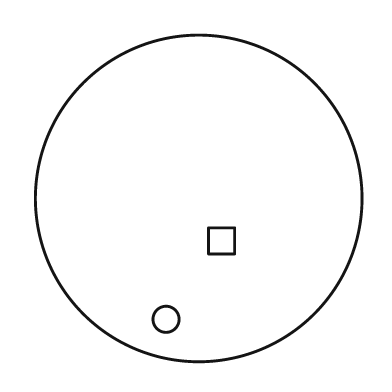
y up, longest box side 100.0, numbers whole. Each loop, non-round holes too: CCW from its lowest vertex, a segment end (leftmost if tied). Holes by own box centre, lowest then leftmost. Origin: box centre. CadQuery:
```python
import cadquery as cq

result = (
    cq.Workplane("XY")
    .moveTo(0.0, 0.0)
    .circle(50.0)
    .moveTo(-10.0, -37.0)
    .circle(4.0)
    .moveTo(3.0, -17.0)
    .lineTo(11.0, -17.0)
    .lineTo(11.0, -9.0)
    .lineTo(3.0, -9.0)
    .close()
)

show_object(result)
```